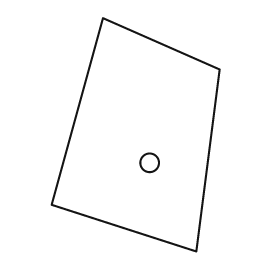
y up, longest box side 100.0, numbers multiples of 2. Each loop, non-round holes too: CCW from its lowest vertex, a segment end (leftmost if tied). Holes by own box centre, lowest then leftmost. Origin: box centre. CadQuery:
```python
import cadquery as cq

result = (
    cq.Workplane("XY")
    .moveTo(26.0, -50.0)
    .lineTo(36.0, 28.0)
    .lineTo(-14.0, 50.0)
    .lineTo(-36.0, -30.0)
    .close()
    .moveTo(6.0, -12.0)
    .circle(4.0)
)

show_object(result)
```